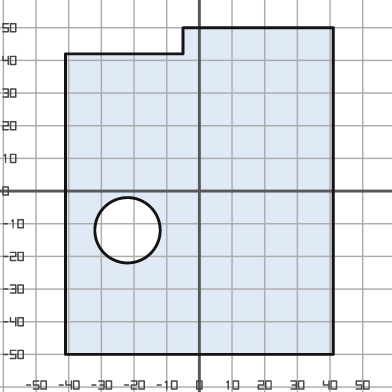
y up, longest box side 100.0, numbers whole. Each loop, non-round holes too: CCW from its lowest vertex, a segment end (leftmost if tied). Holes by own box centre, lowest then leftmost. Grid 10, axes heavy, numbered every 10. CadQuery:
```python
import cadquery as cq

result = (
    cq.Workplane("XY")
    .moveTo(-41.0, -50.0)
    .lineTo(41.0, -50.0)
    .lineTo(41.0, 50.0)
    .lineTo(-5.0, 50.0)
    .lineTo(-5.0, 42.0)
    .lineTo(-41.0, 42.0)
    .close()
    .moveTo(-22.0, -12.0)
    .circle(10.0)
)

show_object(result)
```